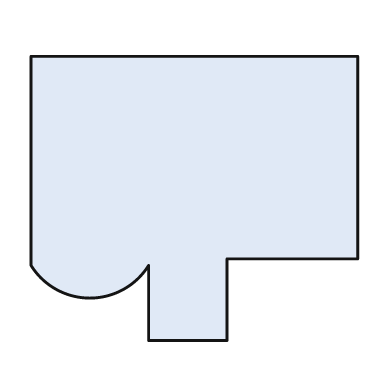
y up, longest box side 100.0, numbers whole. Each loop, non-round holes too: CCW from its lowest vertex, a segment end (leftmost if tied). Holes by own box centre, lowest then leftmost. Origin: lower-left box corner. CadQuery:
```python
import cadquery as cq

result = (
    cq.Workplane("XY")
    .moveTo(36.0, 0.0)
    .lineTo(60.0, 0.0)
    .lineTo(60.0, 25.0)
    .lineTo(100.0, 25.0)
    .lineTo(100.0, 87.0)
    .lineTo(0.0, 87.0)
    .lineTo(0.0, 23.0)
    .threePointArc((18.0, 13.0), (36.0, 23.0))
    .close()
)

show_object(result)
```